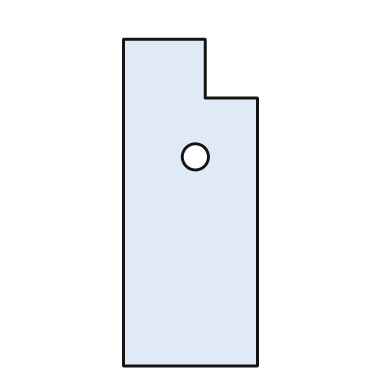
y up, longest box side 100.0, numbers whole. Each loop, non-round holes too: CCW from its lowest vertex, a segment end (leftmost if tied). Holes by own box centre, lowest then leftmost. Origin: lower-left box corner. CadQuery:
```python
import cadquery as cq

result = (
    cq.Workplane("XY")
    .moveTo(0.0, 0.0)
    .lineTo(41.0, 0.0)
    .lineTo(41.0, 82.0)
    .lineTo(25.0, 82.0)
    .lineTo(25.0, 100.0)
    .lineTo(0.0, 100.0)
    .close()
    .moveTo(22.0, 64.0)
    .circle(4.0)
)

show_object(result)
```